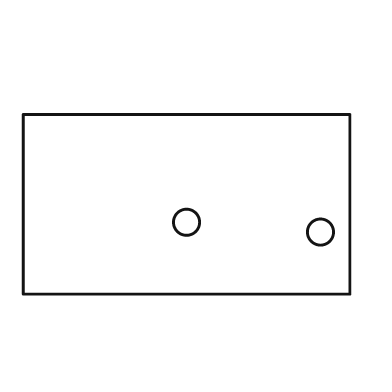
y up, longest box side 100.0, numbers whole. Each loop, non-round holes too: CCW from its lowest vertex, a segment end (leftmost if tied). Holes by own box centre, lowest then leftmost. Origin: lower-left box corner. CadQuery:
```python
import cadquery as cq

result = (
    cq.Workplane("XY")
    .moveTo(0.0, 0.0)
    .lineTo(100.0, 0.0)
    .lineTo(100.0, 55.0)
    .lineTo(0.0, 55.0)
    .close()
    .moveTo(91.0, 19.0)
    .circle(4.0)
    .moveTo(50.0, 22.0)
    .circle(4.0)
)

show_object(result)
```